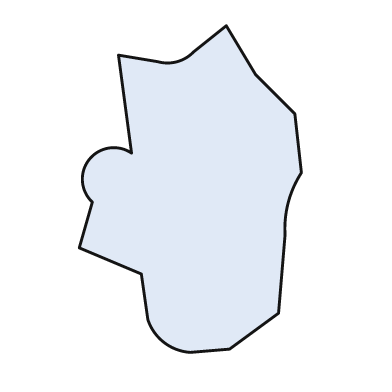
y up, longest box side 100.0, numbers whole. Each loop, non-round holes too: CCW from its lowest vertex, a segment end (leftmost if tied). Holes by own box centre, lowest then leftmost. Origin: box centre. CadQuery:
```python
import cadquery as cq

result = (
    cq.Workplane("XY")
    .moveTo(0.0, -50.0)
    .lineTo(12.0, -49.0)
    .lineTo(27.0, -38.0)
    .lineTo(29.0, -14.0)
    .threePointArc((30.0, -4.0), (34.0, 5.0))
    .lineTo(32.0, 23.0)
    .lineTo(20.0, 35.0)
    .lineTo(11.0, 50.0)
    .lineTo(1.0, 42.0)
    .threePointArc((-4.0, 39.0), (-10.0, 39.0))
    .lineTo(-22.0, 41.0)
    .lineTo(-18.0, 11.0)
    .threePointArc((-31.0, 9.0), (-30.0, -4.0))
    .lineTo(-34.0, -18.0)
    .lineTo(-15.0, -26.0)
    .lineTo(-13.0, -40.0)
    .threePointArc((-8.0, -47.0), (0.0, -50.0))
    .close()
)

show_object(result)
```